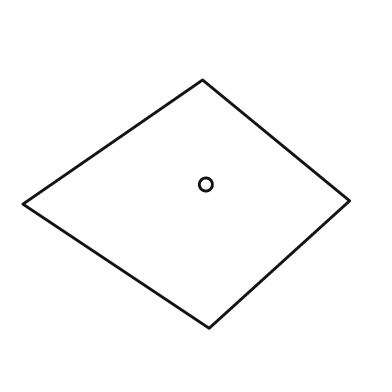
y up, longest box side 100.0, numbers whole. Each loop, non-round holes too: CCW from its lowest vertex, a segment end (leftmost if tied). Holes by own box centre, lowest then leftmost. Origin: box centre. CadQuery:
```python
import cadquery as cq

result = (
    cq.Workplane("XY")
    .moveTo(7.0, -38.0)
    .lineTo(50.0, 1.0)
    .lineTo(5.0, 38.0)
    .lineTo(-50.0, 0.0)
    .close()
    .moveTo(6.0, 6.0)
    .circle(2.0)
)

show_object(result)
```